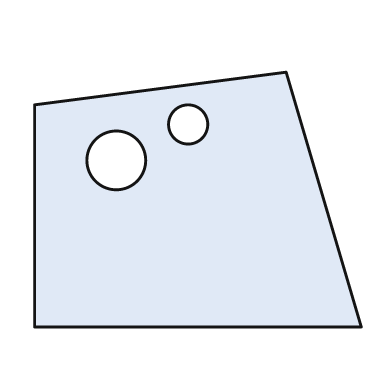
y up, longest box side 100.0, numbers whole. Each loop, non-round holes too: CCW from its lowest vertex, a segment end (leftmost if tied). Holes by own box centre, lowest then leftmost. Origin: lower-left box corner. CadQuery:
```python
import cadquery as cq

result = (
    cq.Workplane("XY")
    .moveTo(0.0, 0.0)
    .lineTo(100.0, 0.0)
    .lineTo(77.0, 78.0)
    .lineTo(0.0, 68.0)
    .close()
    .moveTo(25.0, 51.0)
    .circle(9.0)
    .moveTo(47.0, 62.0)
    .circle(6.0)
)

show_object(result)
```